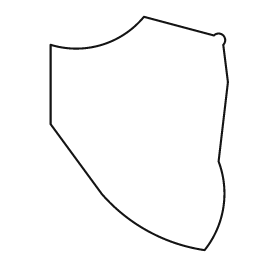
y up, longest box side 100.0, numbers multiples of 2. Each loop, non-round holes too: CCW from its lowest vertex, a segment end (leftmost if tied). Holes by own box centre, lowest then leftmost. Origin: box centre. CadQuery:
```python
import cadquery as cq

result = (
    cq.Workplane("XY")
    .moveTo(28.0, -50.0)
    .threePointArc((36.0, -32.0), (34.0, -12.0))
    .lineTo(38.0, 22.0)
    .lineTo(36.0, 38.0)
    .threePointArc((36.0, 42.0), (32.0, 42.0))
    .lineTo(2.0, 50.0)
    .threePointArc((-16.0, 38.0), (-38.0, 38.0))
    .lineTo(-38.0, 4.0)
    .lineTo(-16.0, -26.0)
    .threePointArc((4.0, -42.0), (28.0, -50.0))
    .close()
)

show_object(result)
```